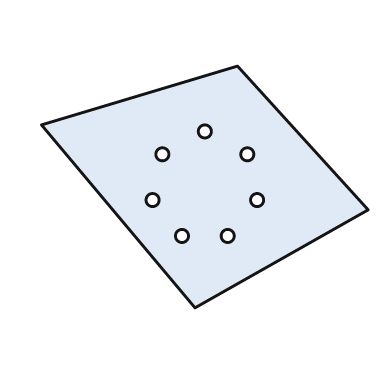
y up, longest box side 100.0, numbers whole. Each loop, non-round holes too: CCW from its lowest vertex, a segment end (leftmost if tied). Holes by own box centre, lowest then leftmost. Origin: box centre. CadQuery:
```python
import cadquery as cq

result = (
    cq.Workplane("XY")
    .moveTo(-3.0, -37.0)
    .lineTo(50.0, -7.0)
    .lineTo(10.0, 37.0)
    .lineTo(-50.0, 19.0)
    .close()
    .moveTo(-7.0, -15.0)
    .circle(2.0)
    .moveTo(7.0, -15.0)
    .circle(2.0)
    .moveTo(-16.0, -4.0)
    .circle(2.0)
    .moveTo(16.0, -4.0)
    .circle(2.0)
    .moveTo(-13.0, 10.0)
    .circle(2.0)
    .moveTo(13.0, 10.0)
    .circle(2.0)
    .moveTo(0.0, 17.0)
    .circle(2.0)
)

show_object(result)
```